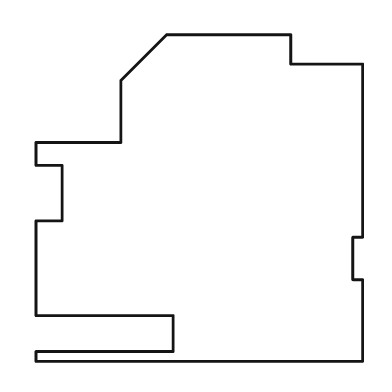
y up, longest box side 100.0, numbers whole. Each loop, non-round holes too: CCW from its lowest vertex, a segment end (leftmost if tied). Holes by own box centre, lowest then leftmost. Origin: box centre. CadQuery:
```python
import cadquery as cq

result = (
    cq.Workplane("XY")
    .moveTo(-50.0, -50.0)
    .lineTo(50.0, -50.0)
    .lineTo(50.0, -25.0)
    .lineTo(47.0, -25.0)
    .lineTo(47.0, -12.0)
    .lineTo(50.0, -12.0)
    .lineTo(50.0, 41.0)
    .lineTo(28.0, 41.0)
    .lineTo(28.0, 50.0)
    .lineTo(-10.0, 50.0)
    .lineTo(-24.0, 36.0)
    .lineTo(-24.0, 17.0)
    .lineTo(-50.0, 17.0)
    .lineTo(-50.0, 10.0)
    .lineTo(-42.0, 10.0)
    .lineTo(-42.0, -7.0)
    .lineTo(-50.0, -7.0)
    .lineTo(-50.0, -36.0)
    .lineTo(-8.0, -36.0)
    .lineTo(-8.0, -47.0)
    .lineTo(-50.0, -47.0)
    .close()
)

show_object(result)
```